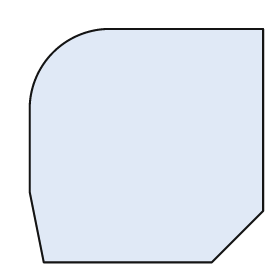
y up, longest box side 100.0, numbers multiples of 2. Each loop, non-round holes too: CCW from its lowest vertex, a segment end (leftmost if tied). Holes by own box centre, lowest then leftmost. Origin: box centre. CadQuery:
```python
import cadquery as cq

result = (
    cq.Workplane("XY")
    .moveTo(-44.0, -50.0)
    .lineTo(28.0, -50.0)
    .lineTo(50.0, -28.0)
    .lineTo(50.0, 50.0)
    .lineTo(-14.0, 50.0)
    .threePointArc((-40.0, 40.0), (-50.0, 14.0))
    .lineTo(-50.0, -20.0)
    .close()
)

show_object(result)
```